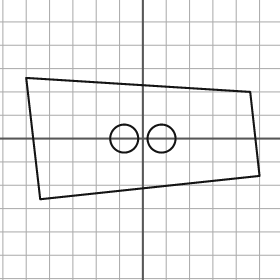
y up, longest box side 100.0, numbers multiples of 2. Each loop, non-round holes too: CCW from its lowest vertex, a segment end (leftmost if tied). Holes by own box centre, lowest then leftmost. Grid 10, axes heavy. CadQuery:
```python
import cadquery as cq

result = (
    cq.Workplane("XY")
    .moveTo(-44.0, -26.0)
    .lineTo(50.0, -16.0)
    .lineTo(46.0, 20.0)
    .lineTo(-50.0, 26.0)
    .close()
    .moveTo(-8.0, 0.0)
    .circle(6.0)
    .moveTo(8.0, 0.0)
    .circle(6.0)
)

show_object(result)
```